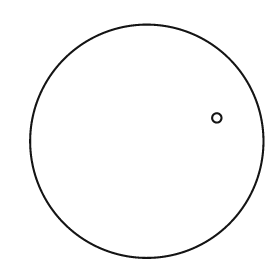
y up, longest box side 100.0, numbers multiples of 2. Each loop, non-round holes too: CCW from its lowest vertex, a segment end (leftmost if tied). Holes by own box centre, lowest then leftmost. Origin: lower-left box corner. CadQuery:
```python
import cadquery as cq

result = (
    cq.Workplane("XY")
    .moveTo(50.0, 50.0)
    .circle(50.0)
    .moveTo(80.0, 60.0)
    .circle(2.0)
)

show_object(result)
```